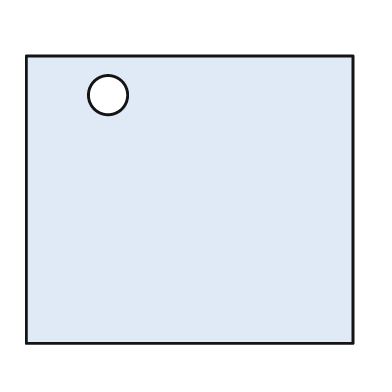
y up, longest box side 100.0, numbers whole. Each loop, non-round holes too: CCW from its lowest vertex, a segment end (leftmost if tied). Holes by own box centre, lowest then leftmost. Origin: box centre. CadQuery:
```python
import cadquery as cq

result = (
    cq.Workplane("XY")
    .moveTo(-50.0, -44.0)
    .lineTo(50.0, -44.0)
    .lineTo(50.0, 44.0)
    .lineTo(-50.0, 44.0)
    .close()
    .moveTo(-25.0, 32.0)
    .circle(6.0)
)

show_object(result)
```